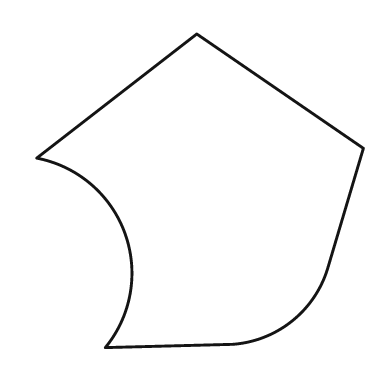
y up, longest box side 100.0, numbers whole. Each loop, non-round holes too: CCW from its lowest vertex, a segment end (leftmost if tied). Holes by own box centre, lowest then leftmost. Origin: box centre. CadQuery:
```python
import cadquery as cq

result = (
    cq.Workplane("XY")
    .moveTo(-29.0, -48.0)
    .lineTo(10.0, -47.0)
    .threePointArc((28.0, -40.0), (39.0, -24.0))
    .lineTo(50.0, 13.0)
    .lineTo(-1.0, 48.0)
    .lineTo(-50.0, 10.0)
    .threePointArc((-23.0, -13.0), (-29.0, -48.0))
    .close()
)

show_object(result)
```